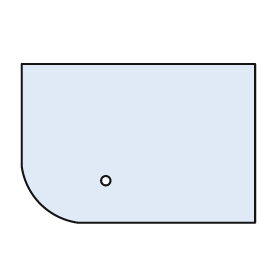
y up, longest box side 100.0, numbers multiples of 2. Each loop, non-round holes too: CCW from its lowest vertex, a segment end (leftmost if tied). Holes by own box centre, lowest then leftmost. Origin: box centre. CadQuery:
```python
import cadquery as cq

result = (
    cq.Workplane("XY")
    .moveTo(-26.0, -34.0)
    .lineTo(50.0, -34.0)
    .lineTo(50.0, 34.0)
    .lineTo(-50.0, 34.0)
    .lineTo(-50.0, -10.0)
    .threePointArc((-42.0, -26.0), (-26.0, -34.0))
    .close()
    .moveTo(-14.0, -16.0)
    .circle(2.0)
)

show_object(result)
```